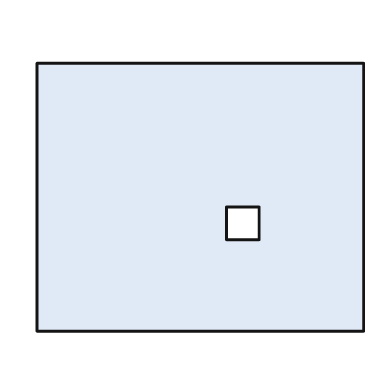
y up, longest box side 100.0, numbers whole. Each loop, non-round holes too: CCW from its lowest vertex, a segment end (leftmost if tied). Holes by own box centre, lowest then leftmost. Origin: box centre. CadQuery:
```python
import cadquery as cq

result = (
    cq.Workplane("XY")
    .moveTo(-50.0, -41.0)
    .lineTo(50.0, -41.0)
    .lineTo(50.0, 41.0)
    .lineTo(-50.0, 41.0)
    .close()
    .moveTo(8.0, -13.0)
    .lineTo(18.0, -13.0)
    .lineTo(18.0, -3.0)
    .lineTo(8.0, -3.0)
    .close()
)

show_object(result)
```